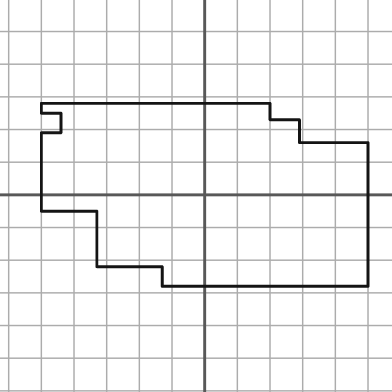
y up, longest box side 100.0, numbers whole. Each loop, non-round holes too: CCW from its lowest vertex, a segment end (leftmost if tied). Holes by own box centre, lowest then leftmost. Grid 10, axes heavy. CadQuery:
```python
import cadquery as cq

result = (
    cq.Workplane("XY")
    .moveTo(-13.0, -28.0)
    .lineTo(50.0, -28.0)
    .lineTo(50.0, 16.0)
    .lineTo(29.0, 16.0)
    .lineTo(29.0, 23.0)
    .lineTo(20.0, 23.0)
    .lineTo(20.0, 28.0)
    .lineTo(-50.0, 28.0)
    .lineTo(-50.0, 25.0)
    .lineTo(-44.0, 25.0)
    .lineTo(-44.0, 19.0)
    .lineTo(-50.0, 19.0)
    .lineTo(-50.0, -5.0)
    .lineTo(-33.0, -5.0)
    .lineTo(-33.0, -22.0)
    .lineTo(-13.0, -22.0)
    .close()
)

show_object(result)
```